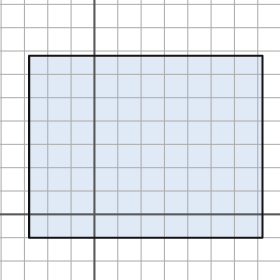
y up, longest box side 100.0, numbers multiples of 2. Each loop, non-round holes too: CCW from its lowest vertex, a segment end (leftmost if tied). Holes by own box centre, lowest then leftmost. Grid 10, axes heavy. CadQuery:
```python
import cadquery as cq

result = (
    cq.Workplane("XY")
    .moveTo(-28.0, -10.0)
    .lineTo(72.0, -10.0)
    .lineTo(72.0, 68.0)
    .lineTo(-28.0, 68.0)
    .close()
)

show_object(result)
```